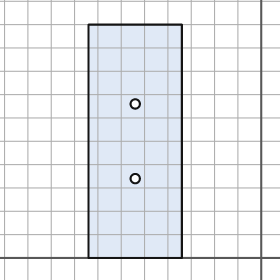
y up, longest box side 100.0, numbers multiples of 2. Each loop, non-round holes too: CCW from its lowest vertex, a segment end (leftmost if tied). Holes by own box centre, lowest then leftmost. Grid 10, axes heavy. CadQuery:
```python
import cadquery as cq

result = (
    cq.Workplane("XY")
    .moveTo(-74.0, 0.0)
    .lineTo(-34.0, 0.0)
    .lineTo(-34.0, 100.0)
    .lineTo(-74.0, 100.0)
    .close()
    .moveTo(-54.0, 34.0)
    .circle(2.0)
    .moveTo(-54.0, 66.0)
    .circle(2.0)
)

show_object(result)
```